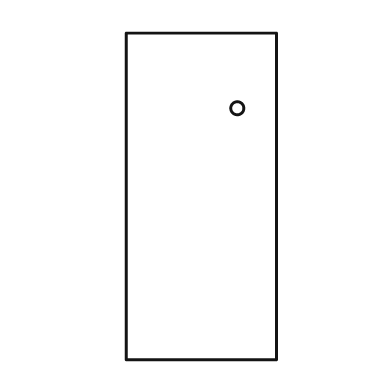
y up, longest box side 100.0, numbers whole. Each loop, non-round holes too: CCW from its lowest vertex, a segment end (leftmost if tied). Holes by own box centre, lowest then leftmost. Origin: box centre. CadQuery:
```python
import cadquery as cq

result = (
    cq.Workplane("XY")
    .moveTo(-23.0, -50.0)
    .lineTo(23.0, -50.0)
    .lineTo(23.0, 50.0)
    .lineTo(-23.0, 50.0)
    .close()
    .moveTo(11.0, 27.0)
    .circle(2.0)
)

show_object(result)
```